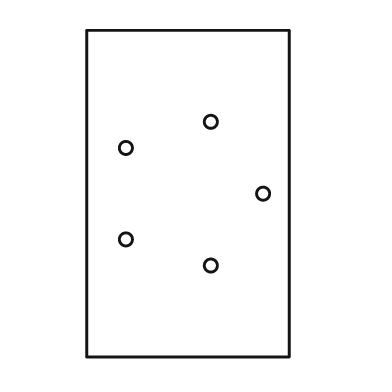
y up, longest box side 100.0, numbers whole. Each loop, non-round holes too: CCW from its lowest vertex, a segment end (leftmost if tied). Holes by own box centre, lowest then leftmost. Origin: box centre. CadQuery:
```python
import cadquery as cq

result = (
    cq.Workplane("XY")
    .moveTo(-31.0, -50.0)
    .lineTo(31.0, -50.0)
    .lineTo(31.0, 50.0)
    .lineTo(-31.0, 50.0)
    .close()
    .moveTo(7.0, -22.0)
    .circle(2.0)
    .moveTo(-19.0, -14.0)
    .circle(2.0)
    .moveTo(23.0, 0.0)
    .circle(2.0)
    .moveTo(-19.0, 14.0)
    .circle(2.0)
    .moveTo(7.0, 22.0)
    .circle(2.0)
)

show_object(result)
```